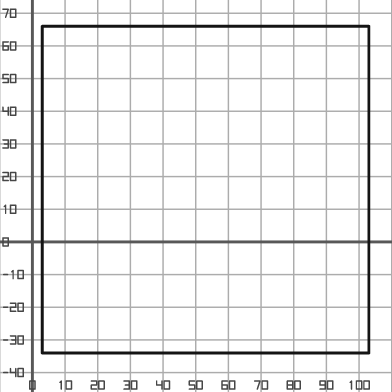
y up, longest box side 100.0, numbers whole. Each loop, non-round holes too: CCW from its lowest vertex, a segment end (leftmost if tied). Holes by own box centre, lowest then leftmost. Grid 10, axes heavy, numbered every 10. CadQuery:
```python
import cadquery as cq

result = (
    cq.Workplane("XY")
    .moveTo(3.0, -34.0)
    .lineTo(103.0, -34.0)
    .lineTo(103.0, 66.0)
    .lineTo(3.0, 66.0)
    .close()
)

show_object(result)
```